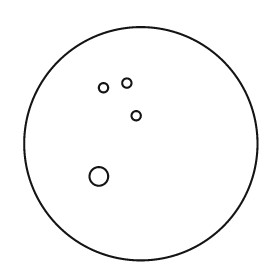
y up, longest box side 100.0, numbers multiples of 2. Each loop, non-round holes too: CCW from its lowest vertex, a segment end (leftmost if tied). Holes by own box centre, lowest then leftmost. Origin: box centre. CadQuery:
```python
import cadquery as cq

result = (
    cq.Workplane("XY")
    .moveTo(0.0, 0.0)
    .circle(50.0)
    .moveTo(-18.0, -14.0)
    .circle(4.0)
    .moveTo(-2.0, 12.0)
    .circle(2.0)
    .moveTo(-16.0, 24.0)
    .circle(2.0)
    .moveTo(-6.0, 26.0)
    .circle(2.0)
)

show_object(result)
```